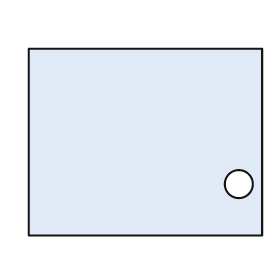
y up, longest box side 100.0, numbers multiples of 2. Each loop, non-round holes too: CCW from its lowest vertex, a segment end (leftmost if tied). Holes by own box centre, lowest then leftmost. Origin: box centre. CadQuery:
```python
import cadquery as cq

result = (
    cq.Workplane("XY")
    .moveTo(-50.0, -40.0)
    .lineTo(50.0, -40.0)
    .lineTo(50.0, 40.0)
    .lineTo(-50.0, 40.0)
    .close()
    .moveTo(40.0, -18.0)
    .circle(6.0)
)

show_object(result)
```